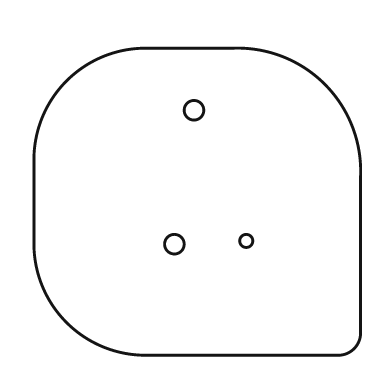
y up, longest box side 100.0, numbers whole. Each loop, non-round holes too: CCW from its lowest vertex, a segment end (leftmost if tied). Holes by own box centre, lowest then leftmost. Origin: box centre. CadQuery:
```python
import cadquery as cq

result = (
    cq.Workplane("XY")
    .moveTo(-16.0, -47.0)
    .lineTo(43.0, -47.0)
    .threePointArc((48.0, -45.0), (50.0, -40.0))
    .lineTo(50.0, 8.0)
    .threePointArc((39.0, 36.0), (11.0, 47.0))
    .lineTo(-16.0, 47.0)
    .threePointArc((-40.0, 37.0), (-50.0, 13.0))
    .lineTo(-50.0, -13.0)
    .threePointArc((-40.0, -37.0), (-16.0, -47.0))
    .close()
    .moveTo(-7.0, -13.0)
    .circle(3.0)
    .moveTo(15.0, -12.0)
    .circle(2.0)
    .moveTo(-1.0, 28.0)
    .circle(3.0)
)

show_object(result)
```